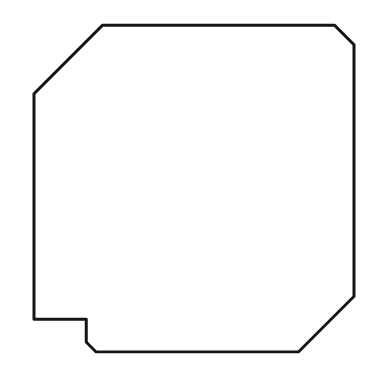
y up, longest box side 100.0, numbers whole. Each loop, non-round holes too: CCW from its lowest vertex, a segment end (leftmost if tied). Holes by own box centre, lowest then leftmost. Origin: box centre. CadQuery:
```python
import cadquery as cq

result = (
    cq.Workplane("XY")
    .moveTo(-30.0, -50.0)
    .lineTo(32.0, -50.0)
    .lineTo(49.0, -33.0)
    .lineTo(49.0, 44.0)
    .lineTo(43.0, 50.0)
    .lineTo(-28.0, 50.0)
    .lineTo(-49.0, 29.0)
    .lineTo(-49.0, -40.0)
    .lineTo(-33.0, -40.0)
    .lineTo(-33.0, -47.0)
    .close()
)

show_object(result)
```